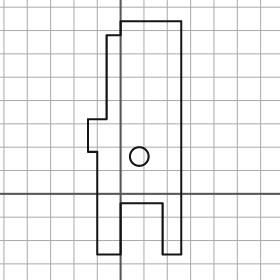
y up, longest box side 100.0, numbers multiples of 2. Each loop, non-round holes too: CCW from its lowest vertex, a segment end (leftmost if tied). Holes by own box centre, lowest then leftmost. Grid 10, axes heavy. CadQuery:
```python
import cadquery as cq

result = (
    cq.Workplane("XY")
    .moveTo(-10.0, -26.0)
    .lineTo(0.0, -26.0)
    .lineTo(0.0, -4.0)
    .lineTo(18.0, -4.0)
    .lineTo(18.0, -26.0)
    .lineTo(26.0, -26.0)
    .lineTo(26.0, 74.0)
    .lineTo(0.0, 74.0)
    .lineTo(0.0, 68.0)
    .lineTo(-6.0, 68.0)
    .lineTo(-6.0, 32.0)
    .lineTo(-14.0, 32.0)
    .lineTo(-14.0, 18.0)
    .lineTo(-10.0, 18.0)
    .close()
    .moveTo(8.0, 16.0)
    .circle(4.0)
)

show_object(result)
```